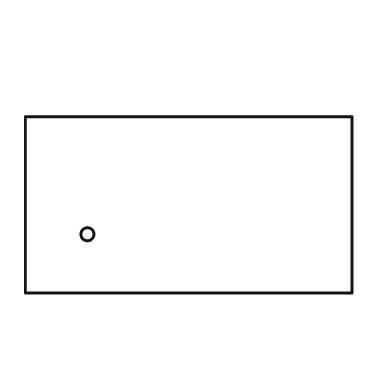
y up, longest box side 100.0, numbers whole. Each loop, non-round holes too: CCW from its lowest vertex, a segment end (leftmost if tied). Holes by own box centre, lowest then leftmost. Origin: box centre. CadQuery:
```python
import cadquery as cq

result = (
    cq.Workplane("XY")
    .moveTo(-50.0, -27.0)
    .lineTo(50.0, -27.0)
    .lineTo(50.0, 27.0)
    .lineTo(-50.0, 27.0)
    .close()
    .moveTo(-31.0, -9.0)
    .circle(2.0)
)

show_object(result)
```